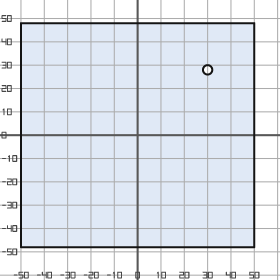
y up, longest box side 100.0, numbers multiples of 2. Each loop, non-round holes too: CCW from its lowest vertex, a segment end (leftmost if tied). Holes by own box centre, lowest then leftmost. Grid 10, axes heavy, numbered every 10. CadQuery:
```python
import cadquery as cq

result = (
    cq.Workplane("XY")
    .moveTo(-50.0, -48.0)
    .lineTo(50.0, -48.0)
    .lineTo(50.0, 48.0)
    .lineTo(-50.0, 48.0)
    .close()
    .moveTo(30.0, 28.0)
    .circle(2.0)
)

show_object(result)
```